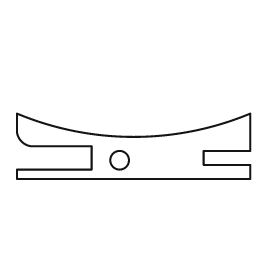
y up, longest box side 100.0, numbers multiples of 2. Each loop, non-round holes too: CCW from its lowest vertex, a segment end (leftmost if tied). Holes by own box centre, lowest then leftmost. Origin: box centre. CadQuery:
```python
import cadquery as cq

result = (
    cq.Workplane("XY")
    .moveTo(-50.0, -14.0)
    .lineTo(50.0, -14.0)
    .lineTo(50.0, -8.0)
    .lineTo(30.0, -8.0)
    .lineTo(30.0, -2.0)
    .lineTo(50.0, -2.0)
    .lineTo(50.0, 14.0)
    .threePointArc((0.0, 4.0), (-50.0, 14.0))
    .lineTo(-50.0, 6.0)
    .threePointArc((-48.0, 2.0), (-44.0, 0.0))
    .lineTo(-18.0, 0.0)
    .lineTo(-18.0, -10.0)
    .lineTo(-50.0, -10.0)
    .close()
    .moveTo(-6.0, -6.0)
    .circle(4.0)
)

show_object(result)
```